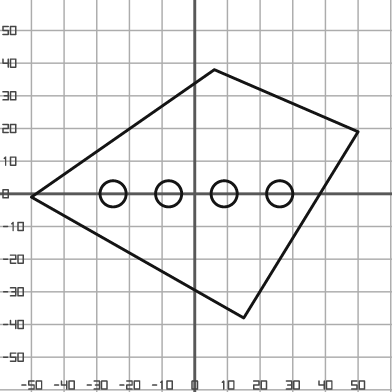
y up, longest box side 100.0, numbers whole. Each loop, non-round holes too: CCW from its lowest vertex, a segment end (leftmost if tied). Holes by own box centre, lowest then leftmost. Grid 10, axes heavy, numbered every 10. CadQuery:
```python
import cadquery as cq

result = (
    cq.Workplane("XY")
    .moveTo(15.0, -38.0)
    .lineTo(50.0, 19.0)
    .lineTo(6.0, 38.0)
    .lineTo(-50.0, -1.0)
    .close()
    .moveTo(-25.0, 0.0)
    .circle(4.0)
    .moveTo(-8.0, 0.0)
    .circle(4.0)
    .moveTo(9.0, 0.0)
    .circle(4.0)
    .moveTo(26.0, 0.0)
    .circle(4.0)
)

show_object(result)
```